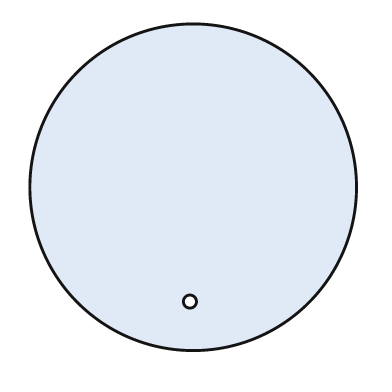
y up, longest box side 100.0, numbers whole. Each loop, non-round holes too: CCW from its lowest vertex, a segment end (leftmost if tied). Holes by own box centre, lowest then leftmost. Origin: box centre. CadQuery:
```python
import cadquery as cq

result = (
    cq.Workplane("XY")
    .moveTo(0.0, 0.0)
    .circle(50.0)
    .moveTo(-1.0, -35.0)
    .circle(2.0)
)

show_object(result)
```